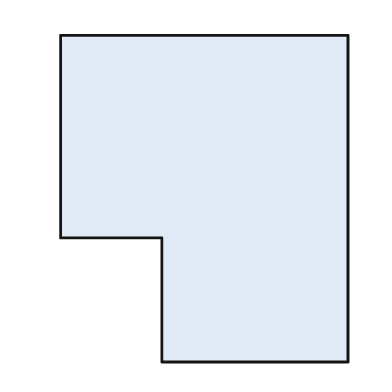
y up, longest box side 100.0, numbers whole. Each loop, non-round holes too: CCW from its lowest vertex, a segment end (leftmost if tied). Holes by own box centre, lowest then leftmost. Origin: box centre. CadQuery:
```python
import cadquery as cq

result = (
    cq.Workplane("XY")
    .moveTo(-13.0, -50.0)
    .lineTo(44.0, -50.0)
    .lineTo(44.0, 50.0)
    .lineTo(-44.0, 50.0)
    .lineTo(-44.0, -12.0)
    .lineTo(-13.0, -12.0)
    .close()
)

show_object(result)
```